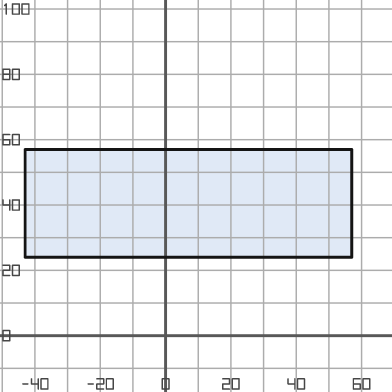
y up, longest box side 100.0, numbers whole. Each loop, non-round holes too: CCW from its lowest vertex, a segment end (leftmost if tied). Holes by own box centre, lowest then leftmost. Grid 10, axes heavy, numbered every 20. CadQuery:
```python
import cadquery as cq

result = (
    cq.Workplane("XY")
    .moveTo(-43.0, 24.0)
    .lineTo(57.0, 24.0)
    .lineTo(57.0, 57.0)
    .lineTo(-43.0, 57.0)
    .close()
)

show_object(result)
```